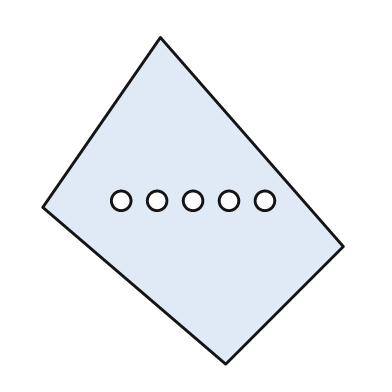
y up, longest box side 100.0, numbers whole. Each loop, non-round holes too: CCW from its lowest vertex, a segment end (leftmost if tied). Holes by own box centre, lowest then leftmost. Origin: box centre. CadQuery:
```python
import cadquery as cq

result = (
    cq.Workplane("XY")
    .moveTo(10.0, -50.0)
    .lineTo(46.0, -14.0)
    .lineTo(-10.0, 50.0)
    .lineTo(-46.0, -2.0)
    .close()
    .moveTo(-22.0, 0.0)
    .circle(3.0)
    .moveTo(-11.0, 0.0)
    .circle(3.0)
    .moveTo(0.0, 0.0)
    .circle(3.0)
    .moveTo(11.0, 0.0)
    .circle(3.0)
    .moveTo(22.0, 0.0)
    .circle(3.0)
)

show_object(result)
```